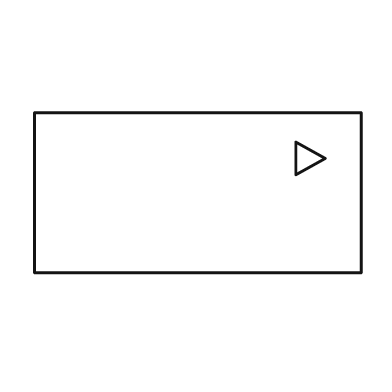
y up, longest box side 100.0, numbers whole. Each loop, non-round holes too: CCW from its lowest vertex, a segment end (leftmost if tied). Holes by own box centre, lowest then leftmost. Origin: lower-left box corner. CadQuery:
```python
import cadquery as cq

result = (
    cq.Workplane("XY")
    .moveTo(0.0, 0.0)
    .lineTo(100.0, 0.0)
    .lineTo(100.0, 49.0)
    .lineTo(0.0, 49.0)
    .close()
    .moveTo(80.0, 30.0)
    .lineTo(89.0, 35.0)
    .lineTo(80.0, 40.0)
    .close()
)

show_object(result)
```